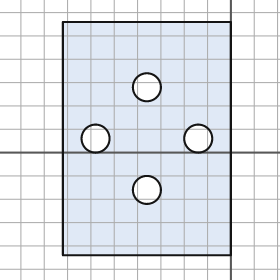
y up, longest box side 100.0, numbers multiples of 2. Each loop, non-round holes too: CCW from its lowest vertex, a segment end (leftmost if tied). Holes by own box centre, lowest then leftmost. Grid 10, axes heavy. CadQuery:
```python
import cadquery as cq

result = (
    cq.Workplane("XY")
    .moveTo(-72.0, -44.0)
    .lineTo(0.0, -44.0)
    .lineTo(0.0, 56.0)
    .lineTo(-72.0, 56.0)
    .close()
    .moveTo(-36.0, -16.0)
    .circle(6.0)
    .moveTo(-58.0, 6.0)
    .circle(6.0)
    .moveTo(-14.0, 6.0)
    .circle(6.0)
    .moveTo(-36.0, 28.0)
    .circle(6.0)
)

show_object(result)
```